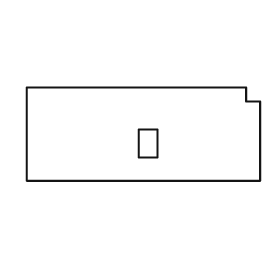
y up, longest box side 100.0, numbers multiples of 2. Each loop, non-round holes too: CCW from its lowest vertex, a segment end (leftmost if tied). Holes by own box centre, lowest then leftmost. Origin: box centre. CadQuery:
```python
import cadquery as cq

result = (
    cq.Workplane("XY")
    .moveTo(-50.0, -20.0)
    .lineTo(50.0, -20.0)
    .lineTo(50.0, 14.0)
    .lineTo(44.0, 14.0)
    .lineTo(44.0, 20.0)
    .lineTo(-50.0, 20.0)
    .close()
    .moveTo(-2.0, -10.0)
    .lineTo(6.0, -10.0)
    .lineTo(6.0, 2.0)
    .lineTo(-2.0, 2.0)
    .close()
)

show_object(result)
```